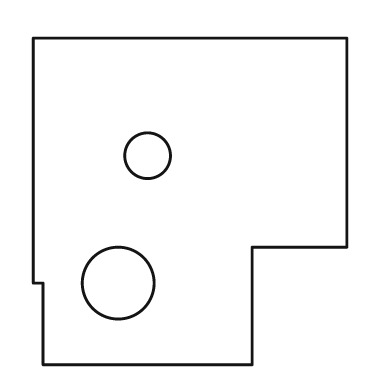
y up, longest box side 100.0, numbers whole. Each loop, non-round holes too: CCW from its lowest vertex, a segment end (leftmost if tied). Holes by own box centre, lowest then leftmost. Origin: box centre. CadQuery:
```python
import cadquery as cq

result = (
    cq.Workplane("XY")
    .moveTo(-45.0, -50.0)
    .lineTo(19.0, -50.0)
    .lineTo(19.0, -14.0)
    .lineTo(48.0, -14.0)
    .lineTo(48.0, 50.0)
    .lineTo(-48.0, 50.0)
    .lineTo(-48.0, -25.0)
    .lineTo(-45.0, -25.0)
    .close()
    .moveTo(-22.0, -25.0)
    .circle(11.0)
    .moveTo(-13.0, 14.0)
    .circle(7.0)
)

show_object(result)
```